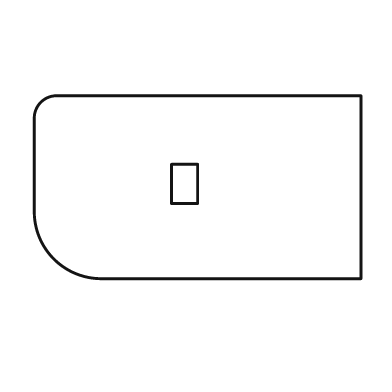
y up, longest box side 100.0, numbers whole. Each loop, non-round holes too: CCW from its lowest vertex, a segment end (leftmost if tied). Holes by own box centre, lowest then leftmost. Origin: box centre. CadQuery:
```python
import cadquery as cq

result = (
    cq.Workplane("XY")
    .moveTo(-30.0, -28.0)
    .lineTo(50.0, -28.0)
    .lineTo(50.0, 28.0)
    .lineTo(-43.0, 28.0)
    .threePointArc((-48.0, 26.0), (-50.0, 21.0))
    .lineTo(-50.0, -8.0)
    .threePointArc((-44.0, -22.0), (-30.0, -28.0))
    .close()
    .moveTo(-8.0, -5.0)
    .lineTo(0.0, -5.0)
    .lineTo(0.0, 7.0)
    .lineTo(-8.0, 7.0)
    .close()
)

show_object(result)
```